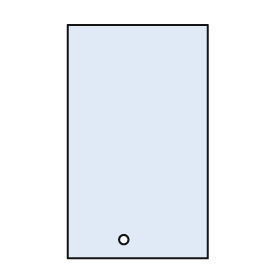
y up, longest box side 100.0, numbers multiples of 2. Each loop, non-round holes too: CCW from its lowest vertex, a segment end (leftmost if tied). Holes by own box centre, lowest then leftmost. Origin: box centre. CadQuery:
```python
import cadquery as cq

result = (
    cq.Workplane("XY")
    .moveTo(-30.0, -50.0)
    .lineTo(30.0, -50.0)
    .lineTo(30.0, 50.0)
    .lineTo(-30.0, 50.0)
    .close()
    .moveTo(-6.0, -42.0)
    .circle(2.0)
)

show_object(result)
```